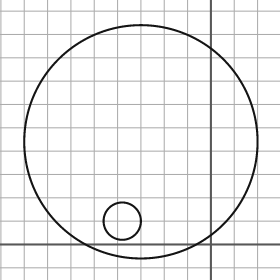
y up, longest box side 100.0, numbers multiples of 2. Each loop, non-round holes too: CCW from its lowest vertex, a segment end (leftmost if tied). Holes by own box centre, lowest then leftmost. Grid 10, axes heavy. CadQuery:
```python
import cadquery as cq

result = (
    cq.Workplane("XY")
    .moveTo(-30.0, 44.0)
    .circle(50.0)
    .moveTo(-38.0, 10.0)
    .circle(8.0)
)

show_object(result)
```